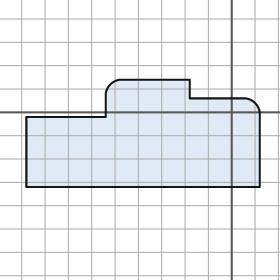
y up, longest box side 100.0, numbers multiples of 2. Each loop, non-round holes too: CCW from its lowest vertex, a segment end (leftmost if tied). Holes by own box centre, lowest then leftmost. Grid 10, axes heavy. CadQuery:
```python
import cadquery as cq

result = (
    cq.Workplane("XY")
    .moveTo(-88.0, -32.0)
    .lineTo(12.0, -32.0)
    .lineTo(12.0, 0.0)
    .threePointArc((10.0, 4.0), (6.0, 6.0))
    .lineTo(-18.0, 6.0)
    .lineTo(-18.0, 14.0)
    .lineTo(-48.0, 14.0)
    .threePointArc((-52.0, 12.0), (-54.0, 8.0))
    .lineTo(-54.0, -2.0)
    .lineTo(-88.0, -2.0)
    .close()
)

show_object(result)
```